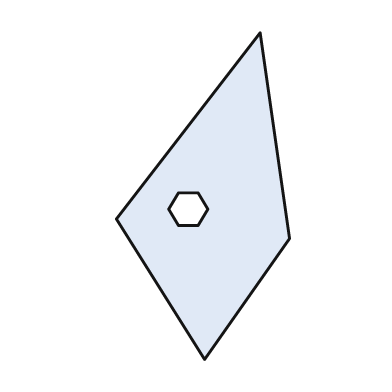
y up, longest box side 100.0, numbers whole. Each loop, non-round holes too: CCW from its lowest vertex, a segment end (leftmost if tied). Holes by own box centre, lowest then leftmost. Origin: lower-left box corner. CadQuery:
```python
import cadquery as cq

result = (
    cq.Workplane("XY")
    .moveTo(27.0, 0.0)
    .lineTo(53.0, 37.0)
    .lineTo(44.0, 100.0)
    .lineTo(0.0, 43.0)
    .close()
    .moveTo(19.0, 41.0)
    .lineTo(25.0, 41.0)
    .lineTo(28.0, 46.0)
    .lineTo(25.0, 51.0)
    .lineTo(19.0, 51.0)
    .lineTo(16.0, 46.0)
    .close()
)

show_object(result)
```